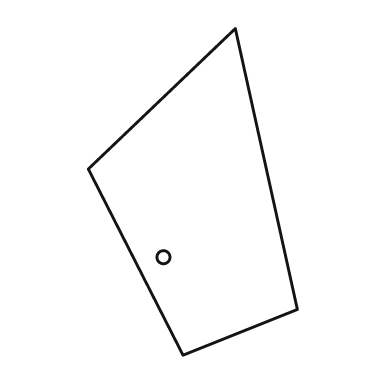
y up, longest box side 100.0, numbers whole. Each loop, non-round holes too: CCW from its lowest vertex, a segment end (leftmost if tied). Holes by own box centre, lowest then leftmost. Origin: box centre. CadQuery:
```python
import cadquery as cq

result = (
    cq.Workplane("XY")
    .moveTo(-3.0, -50.0)
    .lineTo(32.0, -36.0)
    .lineTo(13.0, 50.0)
    .lineTo(-32.0, 7.0)
    .close()
    .moveTo(-9.0, -20.0)
    .circle(2.0)
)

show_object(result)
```